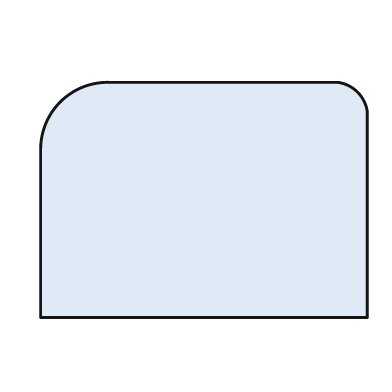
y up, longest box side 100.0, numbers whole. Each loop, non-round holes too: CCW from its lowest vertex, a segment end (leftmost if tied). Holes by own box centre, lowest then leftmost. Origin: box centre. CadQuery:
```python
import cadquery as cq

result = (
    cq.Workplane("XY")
    .moveTo(-50.0, -36.0)
    .lineTo(50.0, -36.0)
    .lineTo(50.0, 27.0)
    .threePointArc((47.0, 33.0), (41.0, 36.0))
    .lineTo(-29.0, 36.0)
    .threePointArc((-44.0, 30.0), (-50.0, 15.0))
    .close()
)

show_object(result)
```